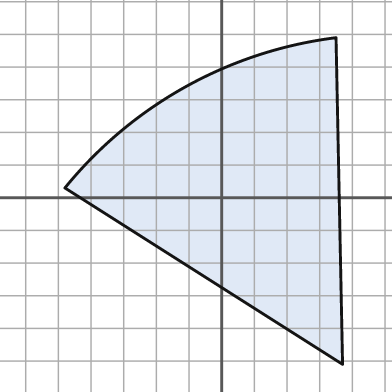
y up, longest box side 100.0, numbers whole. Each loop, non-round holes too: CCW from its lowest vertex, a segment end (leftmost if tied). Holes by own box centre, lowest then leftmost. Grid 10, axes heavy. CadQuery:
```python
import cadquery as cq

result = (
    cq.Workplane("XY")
    .moveTo(37.0, -51.0)
    .lineTo(35.0, 49.0)
    .threePointArc((-11.0, 34.0), (-48.0, 3.0))
    .close()
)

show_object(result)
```